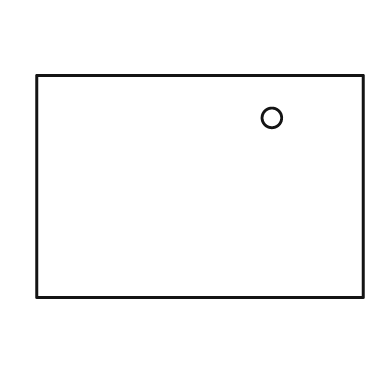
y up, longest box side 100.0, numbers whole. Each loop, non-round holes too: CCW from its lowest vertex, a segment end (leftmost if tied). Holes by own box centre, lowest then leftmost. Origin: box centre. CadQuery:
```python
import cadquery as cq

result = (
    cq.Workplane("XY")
    .moveTo(-50.0, -34.0)
    .lineTo(50.0, -34.0)
    .lineTo(50.0, 34.0)
    .lineTo(-50.0, 34.0)
    .close()
    .moveTo(22.0, 21.0)
    .circle(3.0)
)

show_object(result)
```